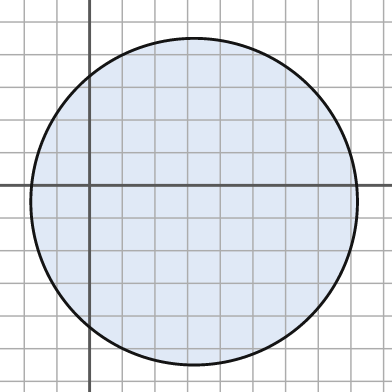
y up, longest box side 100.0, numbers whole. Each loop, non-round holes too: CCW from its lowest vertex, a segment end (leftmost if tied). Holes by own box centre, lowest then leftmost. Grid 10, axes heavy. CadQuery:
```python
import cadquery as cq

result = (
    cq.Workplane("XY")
    .moveTo(32.0, -5.0)
    .circle(50.0)
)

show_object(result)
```